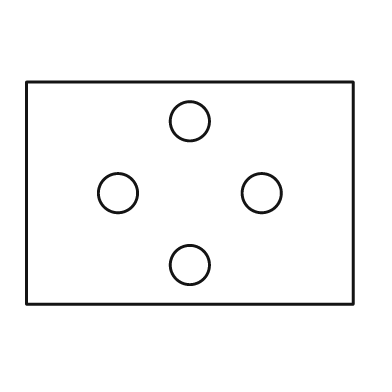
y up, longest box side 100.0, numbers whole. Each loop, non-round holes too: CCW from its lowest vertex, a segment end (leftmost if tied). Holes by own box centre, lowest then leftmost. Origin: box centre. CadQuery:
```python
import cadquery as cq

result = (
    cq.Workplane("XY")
    .moveTo(-50.0, -34.0)
    .lineTo(50.0, -34.0)
    .lineTo(50.0, 34.0)
    .lineTo(-50.0, 34.0)
    .close()
    .moveTo(0.0, -22.0)
    .circle(6.0)
    .moveTo(-22.0, 0.0)
    .circle(6.0)
    .moveTo(22.0, 0.0)
    .circle(6.0)
    .moveTo(0.0, 22.0)
    .circle(6.0)
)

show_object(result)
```